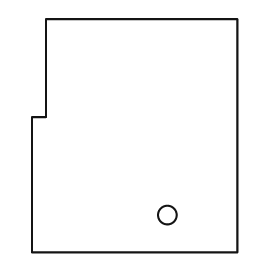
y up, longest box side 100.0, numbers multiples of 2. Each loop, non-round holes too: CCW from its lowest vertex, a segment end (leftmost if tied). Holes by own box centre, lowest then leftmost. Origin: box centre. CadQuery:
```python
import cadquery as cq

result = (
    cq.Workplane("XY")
    .moveTo(-44.0, -50.0)
    .lineTo(44.0, -50.0)
    .lineTo(44.0, 50.0)
    .lineTo(-38.0, 50.0)
    .lineTo(-38.0, 8.0)
    .lineTo(-44.0, 8.0)
    .close()
    .moveTo(14.0, -34.0)
    .circle(4.0)
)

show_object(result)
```